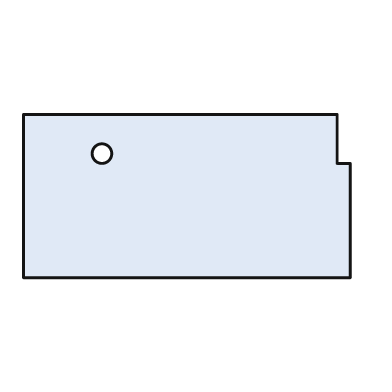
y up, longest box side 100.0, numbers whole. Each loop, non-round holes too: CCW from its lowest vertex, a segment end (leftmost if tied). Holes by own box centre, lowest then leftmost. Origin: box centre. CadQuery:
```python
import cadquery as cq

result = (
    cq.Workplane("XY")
    .moveTo(-50.0, -25.0)
    .lineTo(50.0, -25.0)
    .lineTo(50.0, 10.0)
    .lineTo(46.0, 10.0)
    .lineTo(46.0, 25.0)
    .lineTo(-50.0, 25.0)
    .close()
    .moveTo(-26.0, 13.0)
    .circle(3.0)
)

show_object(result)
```